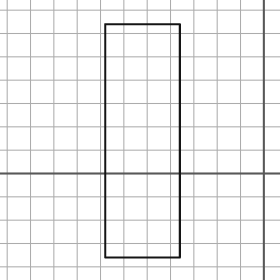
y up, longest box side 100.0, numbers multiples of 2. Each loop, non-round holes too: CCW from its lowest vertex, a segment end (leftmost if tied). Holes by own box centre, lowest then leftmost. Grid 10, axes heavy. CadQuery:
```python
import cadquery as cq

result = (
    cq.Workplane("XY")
    .moveTo(-68.0, -36.0)
    .lineTo(-36.0, -36.0)
    .lineTo(-36.0, 64.0)
    .lineTo(-68.0, 64.0)
    .close()
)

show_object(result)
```